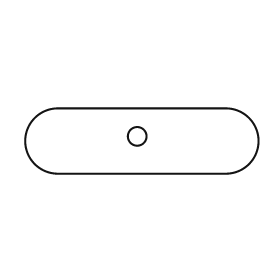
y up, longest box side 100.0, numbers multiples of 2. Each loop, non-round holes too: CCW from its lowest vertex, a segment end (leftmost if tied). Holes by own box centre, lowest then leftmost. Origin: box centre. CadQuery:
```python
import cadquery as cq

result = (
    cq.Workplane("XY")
    .moveTo(-36.0, -14.0)
    .lineTo(36.0, -14.0)
    .threePointArc((50.0, 0.0), (36.0, 14.0))
    .lineTo(-36.0, 14.0)
    .threePointArc((-50.0, 0.0), (-36.0, -14.0))
    .close()
    .moveTo(-2.0, 2.0)
    .circle(4.0)
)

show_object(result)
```